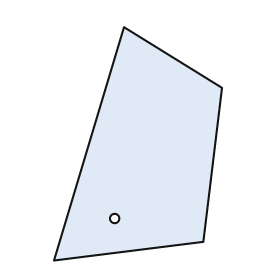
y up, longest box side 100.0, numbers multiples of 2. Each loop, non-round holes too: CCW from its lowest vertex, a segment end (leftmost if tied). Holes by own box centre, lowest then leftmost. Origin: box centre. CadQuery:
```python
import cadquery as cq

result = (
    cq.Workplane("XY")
    .moveTo(-36.0, -50.0)
    .lineTo(28.0, -42.0)
    .lineTo(36.0, 24.0)
    .lineTo(-6.0, 50.0)
    .close()
    .moveTo(-10.0, -32.0)
    .circle(2.0)
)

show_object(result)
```